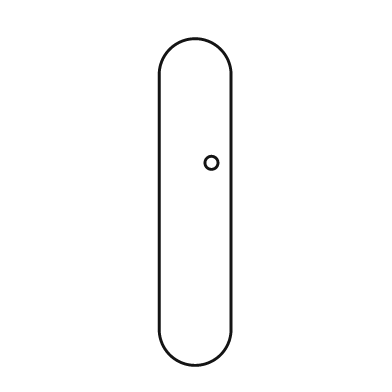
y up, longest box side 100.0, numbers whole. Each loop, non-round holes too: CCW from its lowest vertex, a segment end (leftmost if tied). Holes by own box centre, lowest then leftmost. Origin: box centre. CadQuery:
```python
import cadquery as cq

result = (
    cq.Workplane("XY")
    .moveTo(-11.0, -39.0)
    .threePointArc((0.0, -50.0), (11.0, -39.0))
    .lineTo(11.0, 39.0)
    .threePointArc((0.0, 50.0), (-11.0, 39.0))
    .close()
    .moveTo(5.0, 12.0)
    .circle(2.0)
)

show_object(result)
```